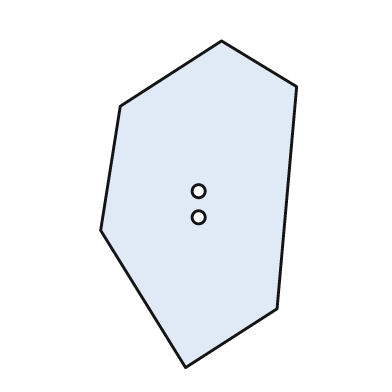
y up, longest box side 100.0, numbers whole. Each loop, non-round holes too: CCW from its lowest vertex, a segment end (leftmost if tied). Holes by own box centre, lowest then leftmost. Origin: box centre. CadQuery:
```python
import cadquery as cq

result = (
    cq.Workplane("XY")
    .moveTo(-4.0, -50.0)
    .lineTo(24.0, -32.0)
    .lineTo(30.0, 36.0)
    .lineTo(7.0, 50.0)
    .lineTo(-24.0, 30.0)
    .lineTo(-30.0, -8.0)
    .close()
    .moveTo(0.0, -4.0)
    .circle(2.0)
    .moveTo(0.0, 4.0)
    .circle(2.0)
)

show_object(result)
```